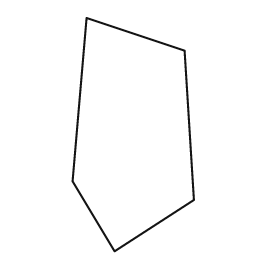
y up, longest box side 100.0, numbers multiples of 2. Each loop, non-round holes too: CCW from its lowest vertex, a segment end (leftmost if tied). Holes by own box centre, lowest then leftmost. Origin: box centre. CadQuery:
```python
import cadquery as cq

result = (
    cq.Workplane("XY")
    .moveTo(-8.0, -50.0)
    .lineTo(26.0, -28.0)
    .lineTo(22.0, 36.0)
    .lineTo(-20.0, 50.0)
    .lineTo(-26.0, -20.0)
    .close()
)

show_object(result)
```